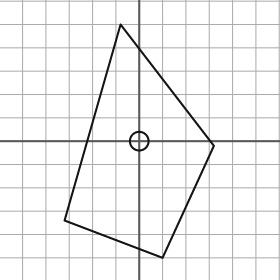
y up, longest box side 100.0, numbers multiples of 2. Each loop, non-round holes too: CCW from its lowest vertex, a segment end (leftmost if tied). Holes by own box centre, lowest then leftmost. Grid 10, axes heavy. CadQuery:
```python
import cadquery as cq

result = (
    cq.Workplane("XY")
    .moveTo(10.0, -50.0)
    .lineTo(32.0, -2.0)
    .lineTo(-8.0, 50.0)
    .lineTo(-32.0, -34.0)
    .close()
    .moveTo(0.0, 0.0)
    .circle(4.0)
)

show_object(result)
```